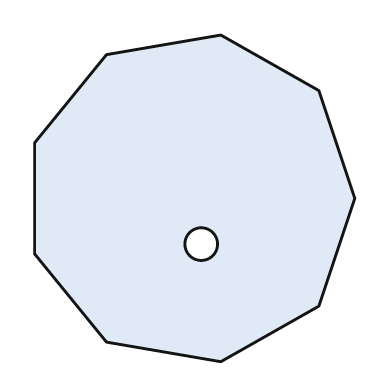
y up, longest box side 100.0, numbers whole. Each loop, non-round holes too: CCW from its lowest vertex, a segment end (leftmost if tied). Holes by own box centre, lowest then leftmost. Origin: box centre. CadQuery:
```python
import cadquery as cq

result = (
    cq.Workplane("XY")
    .moveTo(8.0, -50.0)
    .lineTo(38.0, -33.0)
    .lineTo(49.0, 0.0)
    .lineTo(38.0, 33.0)
    .lineTo(8.0, 50.0)
    .lineTo(-27.0, 44.0)
    .lineTo(-49.0, 17.0)
    .lineTo(-49.0, -17.0)
    .lineTo(-27.0, -44.0)
    .close()
    .moveTo(2.0, -14.0)
    .circle(5.0)
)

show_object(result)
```